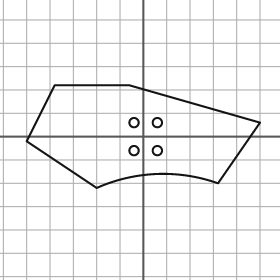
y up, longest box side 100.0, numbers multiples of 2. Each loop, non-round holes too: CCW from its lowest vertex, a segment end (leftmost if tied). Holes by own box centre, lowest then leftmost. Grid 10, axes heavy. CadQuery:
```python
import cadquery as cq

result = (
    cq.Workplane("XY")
    .moveTo(-20.0, -22.0)
    .threePointArc((6.0, -16.0), (32.0, -20.0))
    .lineTo(50.0, 6.0)
    .lineTo(-6.0, 22.0)
    .lineTo(-38.0, 22.0)
    .lineTo(-50.0, -2.0)
    .close()
    .moveTo(-4.0, -6.0)
    .circle(2.0)
    .moveTo(6.0, -6.0)
    .circle(2.0)
    .moveTo(-4.0, 6.0)
    .circle(2.0)
    .moveTo(6.0, 6.0)
    .circle(2.0)
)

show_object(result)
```